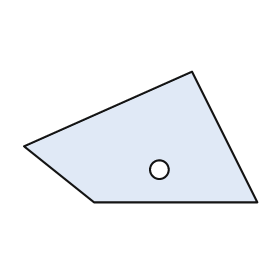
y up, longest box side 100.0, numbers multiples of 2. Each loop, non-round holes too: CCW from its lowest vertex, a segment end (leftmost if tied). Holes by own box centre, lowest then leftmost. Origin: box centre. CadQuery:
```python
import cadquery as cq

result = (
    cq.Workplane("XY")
    .moveTo(-20.0, -28.0)
    .lineTo(50.0, -28.0)
    .lineTo(22.0, 28.0)
    .lineTo(-50.0, -4.0)
    .close()
    .moveTo(8.0, -14.0)
    .circle(4.0)
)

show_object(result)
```